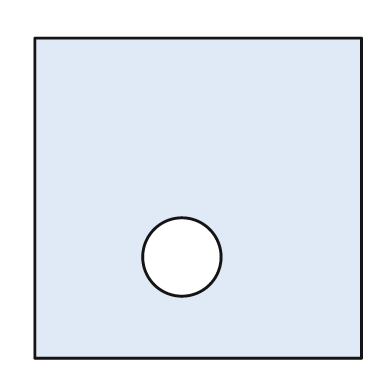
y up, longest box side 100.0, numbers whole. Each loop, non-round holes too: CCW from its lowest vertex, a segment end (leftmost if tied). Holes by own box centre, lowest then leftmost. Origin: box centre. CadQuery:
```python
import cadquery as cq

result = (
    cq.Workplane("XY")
    .moveTo(-50.0, -49.0)
    .lineTo(50.0, -49.0)
    .lineTo(50.0, 49.0)
    .lineTo(-50.0, 49.0)
    .close()
    .moveTo(-5.0, -18.0)
    .circle(12.0)
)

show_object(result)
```